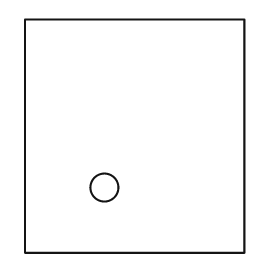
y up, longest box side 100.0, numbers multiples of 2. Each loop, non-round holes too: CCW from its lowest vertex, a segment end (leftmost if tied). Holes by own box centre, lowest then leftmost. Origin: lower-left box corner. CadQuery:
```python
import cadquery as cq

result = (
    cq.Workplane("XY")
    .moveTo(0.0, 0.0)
    .lineTo(94.0, 0.0)
    .lineTo(94.0, 100.0)
    .lineTo(0.0, 100.0)
    .close()
    .moveTo(34.0, 28.0)
    .circle(6.0)
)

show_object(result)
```